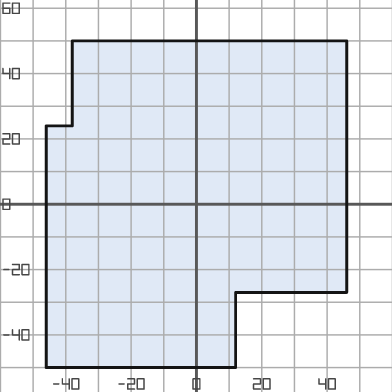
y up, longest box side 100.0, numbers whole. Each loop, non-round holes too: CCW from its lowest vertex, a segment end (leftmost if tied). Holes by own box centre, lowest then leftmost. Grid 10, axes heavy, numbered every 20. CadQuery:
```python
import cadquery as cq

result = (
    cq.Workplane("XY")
    .moveTo(-46.0, -50.0)
    .lineTo(12.0, -50.0)
    .lineTo(12.0, -27.0)
    .lineTo(46.0, -27.0)
    .lineTo(46.0, 50.0)
    .lineTo(-38.0, 50.0)
    .lineTo(-38.0, 24.0)
    .lineTo(-46.0, 24.0)
    .close()
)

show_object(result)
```